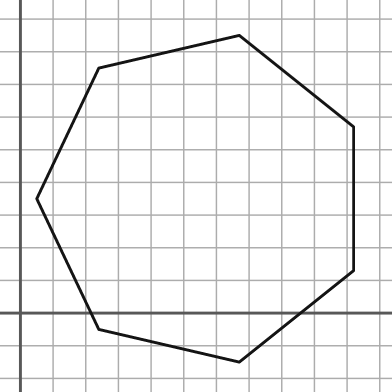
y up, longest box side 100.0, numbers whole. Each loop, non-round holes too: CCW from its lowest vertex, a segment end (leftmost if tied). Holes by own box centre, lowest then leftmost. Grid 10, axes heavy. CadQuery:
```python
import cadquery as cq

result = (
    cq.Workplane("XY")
    .moveTo(67.0, -15.0)
    .lineTo(102.0, 13.0)
    .lineTo(102.0, 57.0)
    .lineTo(67.0, 85.0)
    .lineTo(24.0, 75.0)
    .lineTo(5.0, 35.0)
    .lineTo(24.0, -5.0)
    .close()
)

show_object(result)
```